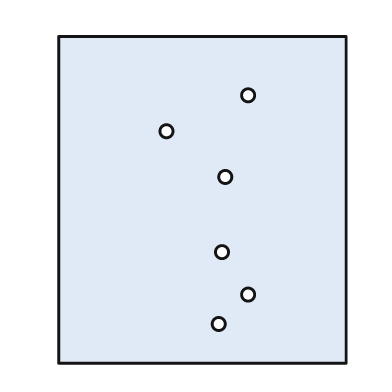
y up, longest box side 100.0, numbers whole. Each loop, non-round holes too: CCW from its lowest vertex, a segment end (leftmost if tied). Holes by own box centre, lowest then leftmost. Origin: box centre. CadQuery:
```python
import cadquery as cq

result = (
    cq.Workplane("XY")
    .moveTo(-44.0, -50.0)
    .lineTo(44.0, -50.0)
    .lineTo(44.0, 50.0)
    .lineTo(-44.0, 50.0)
    .close()
    .moveTo(5.0, -38.0)
    .circle(2.0)
    .moveTo(14.0, -29.0)
    .circle(2.0)
    .moveTo(6.0, -16.0)
    .circle(2.0)
    .moveTo(7.0, 7.0)
    .circle(2.0)
    .moveTo(-11.0, 21.0)
    .circle(2.0)
    .moveTo(14.0, 32.0)
    .circle(2.0)
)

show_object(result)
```